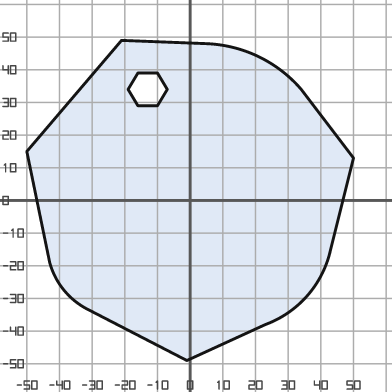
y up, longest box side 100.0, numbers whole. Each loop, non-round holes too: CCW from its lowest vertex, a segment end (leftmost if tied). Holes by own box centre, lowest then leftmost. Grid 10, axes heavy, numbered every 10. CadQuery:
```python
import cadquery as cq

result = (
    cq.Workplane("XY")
    .moveTo(-1.0, -49.0)
    .lineTo(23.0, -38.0)
    .threePointArc((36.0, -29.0), (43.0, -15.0))
    .lineTo(50.0, 13.0)
    .lineTo(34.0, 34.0)
    .threePointArc((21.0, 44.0), (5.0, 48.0))
    .lineTo(-21.0, 49.0)
    .lineTo(-50.0, 15.0)
    .lineTo(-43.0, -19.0)
    .threePointArc((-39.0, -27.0), (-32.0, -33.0))
    .close()
    .moveTo(-16.0, 29.0)
    .lineTo(-10.0, 29.0)
    .lineTo(-7.0, 34.0)
    .lineTo(-10.0, 39.0)
    .lineTo(-16.0, 39.0)
    .lineTo(-19.0, 34.0)
    .close()
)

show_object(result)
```